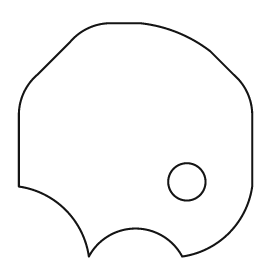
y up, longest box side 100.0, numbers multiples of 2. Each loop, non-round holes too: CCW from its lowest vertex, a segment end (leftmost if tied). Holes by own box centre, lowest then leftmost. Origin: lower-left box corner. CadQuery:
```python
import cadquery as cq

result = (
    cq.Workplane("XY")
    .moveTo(30.0, 0.0)
    .threePointArc((50.0, 12.0), (70.0, 0.0))
    .threePointArc((90.0, 10.0), (100.0, 30.0))
    .lineTo(100.0, 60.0)
    .threePointArc((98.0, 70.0), (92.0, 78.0))
    .lineTo(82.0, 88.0)
    .threePointArc((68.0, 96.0), (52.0, 100.0))
    .lineTo(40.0, 100.0)
    .threePointArc((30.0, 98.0), (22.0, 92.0))
    .lineTo(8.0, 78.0)
    .threePointArc((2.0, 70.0), (0.0, 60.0))
    .lineTo(0.0, 30.0)
    .threePointArc((20.0, 20.0), (30.0, 0.0))
    .close()
    .moveTo(72.0, 32.0)
    .circle(8.0)
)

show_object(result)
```